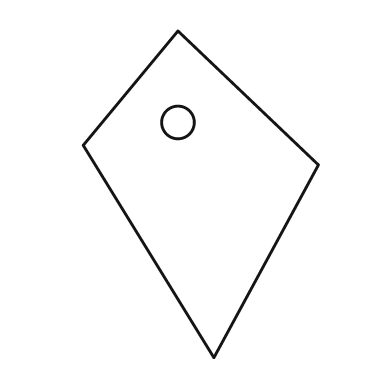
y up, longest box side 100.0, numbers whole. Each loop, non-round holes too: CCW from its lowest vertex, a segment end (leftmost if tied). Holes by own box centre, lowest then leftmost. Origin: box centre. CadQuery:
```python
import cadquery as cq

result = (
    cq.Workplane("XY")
    .moveTo(4.0, -50.0)
    .lineTo(36.0, 9.0)
    .lineTo(-7.0, 50.0)
    .lineTo(-36.0, 15.0)
    .close()
    .moveTo(-7.0, 22.0)
    .circle(5.0)
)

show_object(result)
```